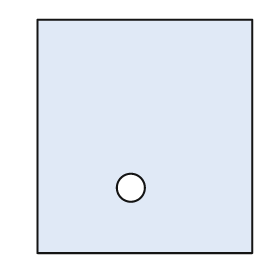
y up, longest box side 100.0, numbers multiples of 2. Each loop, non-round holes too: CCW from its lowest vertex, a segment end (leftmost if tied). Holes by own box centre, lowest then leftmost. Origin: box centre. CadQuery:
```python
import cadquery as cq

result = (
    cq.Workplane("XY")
    .moveTo(-46.0, -50.0)
    .lineTo(46.0, -50.0)
    .lineTo(46.0, 50.0)
    .lineTo(-46.0, 50.0)
    .close()
    .moveTo(-6.0, -22.0)
    .circle(6.0)
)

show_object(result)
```